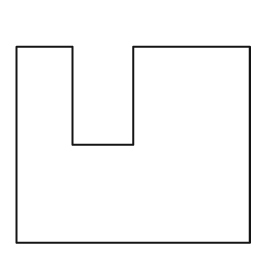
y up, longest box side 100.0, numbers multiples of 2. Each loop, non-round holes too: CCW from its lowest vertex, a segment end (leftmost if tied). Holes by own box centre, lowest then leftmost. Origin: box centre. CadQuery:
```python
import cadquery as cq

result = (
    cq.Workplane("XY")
    .moveTo(-50.0, -42.0)
    .lineTo(50.0, -42.0)
    .lineTo(50.0, 42.0)
    .lineTo(0.0, 42.0)
    .lineTo(0.0, 0.0)
    .lineTo(-26.0, 0.0)
    .lineTo(-26.0, 42.0)
    .lineTo(-50.0, 42.0)
    .close()
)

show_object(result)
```